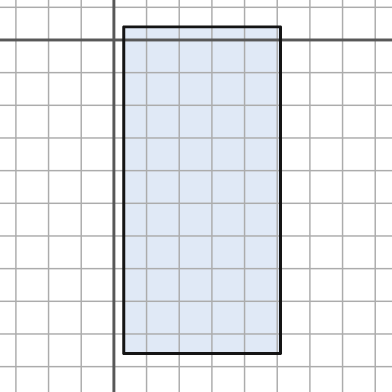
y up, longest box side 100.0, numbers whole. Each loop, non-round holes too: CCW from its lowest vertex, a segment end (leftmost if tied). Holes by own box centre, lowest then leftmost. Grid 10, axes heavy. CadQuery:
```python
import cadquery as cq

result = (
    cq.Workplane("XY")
    .moveTo(3.0, -96.0)
    .lineTo(51.0, -96.0)
    .lineTo(51.0, 4.0)
    .lineTo(3.0, 4.0)
    .close()
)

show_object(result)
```